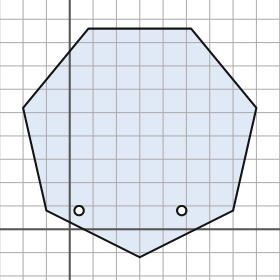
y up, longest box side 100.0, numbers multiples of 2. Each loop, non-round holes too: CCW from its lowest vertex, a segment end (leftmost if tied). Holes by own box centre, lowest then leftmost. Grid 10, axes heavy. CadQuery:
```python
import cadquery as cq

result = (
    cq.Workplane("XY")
    .moveTo(30.0, -12.0)
    .lineTo(70.0, 8.0)
    .lineTo(80.0, 52.0)
    .lineTo(52.0, 86.0)
    .lineTo(8.0, 86.0)
    .lineTo(-20.0, 52.0)
    .lineTo(-10.0, 8.0)
    .close()
    .moveTo(4.0, 8.0)
    .circle(2.0)
    .moveTo(48.0, 8.0)
    .circle(2.0)
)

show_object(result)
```